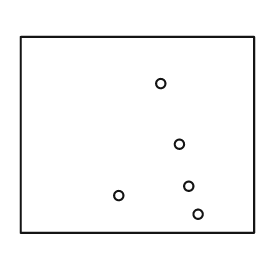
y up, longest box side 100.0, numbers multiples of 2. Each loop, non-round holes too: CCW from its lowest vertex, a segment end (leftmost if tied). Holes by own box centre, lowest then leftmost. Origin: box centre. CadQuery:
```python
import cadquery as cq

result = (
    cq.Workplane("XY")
    .moveTo(-50.0, -42.0)
    .lineTo(50.0, -42.0)
    .lineTo(50.0, 42.0)
    .lineTo(-50.0, 42.0)
    .close()
    .moveTo(26.0, -34.0)
    .circle(2.0)
    .moveTo(-8.0, -26.0)
    .circle(2.0)
    .moveTo(22.0, -22.0)
    .circle(2.0)
    .moveTo(18.0, -4.0)
    .circle(2.0)
    .moveTo(10.0, 22.0)
    .circle(2.0)
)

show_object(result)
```